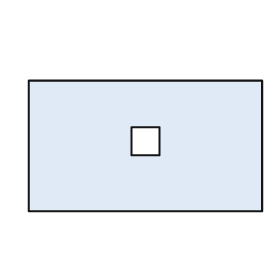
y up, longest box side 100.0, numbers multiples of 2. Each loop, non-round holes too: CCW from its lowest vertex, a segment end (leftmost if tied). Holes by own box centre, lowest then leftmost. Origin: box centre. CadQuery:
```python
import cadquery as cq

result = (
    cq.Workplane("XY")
    .moveTo(-50.0, -28.0)
    .lineTo(50.0, -28.0)
    .lineTo(50.0, 28.0)
    .lineTo(-50.0, 28.0)
    .close()
    .moveTo(-6.0, -4.0)
    .lineTo(6.0, -4.0)
    .lineTo(6.0, 8.0)
    .lineTo(-6.0, 8.0)
    .close()
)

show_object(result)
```